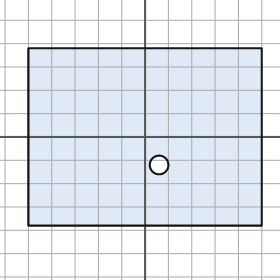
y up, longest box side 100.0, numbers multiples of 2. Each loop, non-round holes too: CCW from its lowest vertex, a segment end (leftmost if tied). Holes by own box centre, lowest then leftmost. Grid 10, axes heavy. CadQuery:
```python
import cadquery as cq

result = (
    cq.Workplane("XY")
    .moveTo(-50.0, -38.0)
    .lineTo(50.0, -38.0)
    .lineTo(50.0, 38.0)
    .lineTo(-50.0, 38.0)
    .close()
    .moveTo(6.0, -12.0)
    .circle(4.0)
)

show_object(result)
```